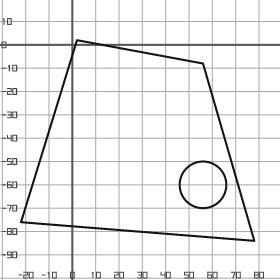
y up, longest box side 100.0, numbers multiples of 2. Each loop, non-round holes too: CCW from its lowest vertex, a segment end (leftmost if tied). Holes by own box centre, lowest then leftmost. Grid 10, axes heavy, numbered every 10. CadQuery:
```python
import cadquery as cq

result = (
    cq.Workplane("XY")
    .moveTo(78.0, -84.0)
    .lineTo(56.0, -8.0)
    .lineTo(2.0, 2.0)
    .lineTo(-22.0, -76.0)
    .close()
    .moveTo(56.0, -60.0)
    .circle(10.0)
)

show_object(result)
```